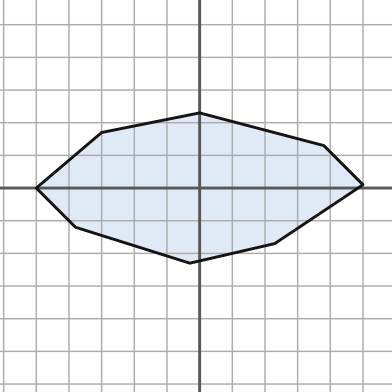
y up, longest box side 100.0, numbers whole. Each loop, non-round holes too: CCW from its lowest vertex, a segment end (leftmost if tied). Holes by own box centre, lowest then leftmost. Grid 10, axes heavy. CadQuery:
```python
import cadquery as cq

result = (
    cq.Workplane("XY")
    .moveTo(-3.0, -23.0)
    .lineTo(23.0, -17.0)
    .lineTo(50.0, 1.0)
    .lineTo(38.0, 13.0)
    .lineTo(0.0, 23.0)
    .lineTo(-30.0, 17.0)
    .lineTo(-50.0, 0.0)
    .lineTo(-38.0, -12.0)
    .close()
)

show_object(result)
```